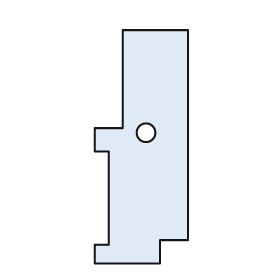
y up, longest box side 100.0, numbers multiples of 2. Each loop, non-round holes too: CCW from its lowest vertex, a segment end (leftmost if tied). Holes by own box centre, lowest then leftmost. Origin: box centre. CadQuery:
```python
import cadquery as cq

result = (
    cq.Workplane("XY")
    .moveTo(-20.0, -50.0)
    .lineTo(8.0, -50.0)
    .lineTo(8.0, -40.0)
    .lineTo(20.0, -40.0)
    .lineTo(20.0, 50.0)
    .lineTo(-8.0, 50.0)
    .lineTo(-8.0, 8.0)
    .lineTo(-20.0, 8.0)
    .lineTo(-20.0, -2.0)
    .lineTo(-14.0, -2.0)
    .lineTo(-14.0, -42.0)
    .lineTo(-20.0, -42.0)
    .close()
    .moveTo(2.0, 6.0)
    .circle(4.0)
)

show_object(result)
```